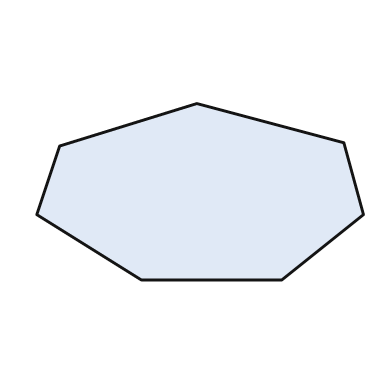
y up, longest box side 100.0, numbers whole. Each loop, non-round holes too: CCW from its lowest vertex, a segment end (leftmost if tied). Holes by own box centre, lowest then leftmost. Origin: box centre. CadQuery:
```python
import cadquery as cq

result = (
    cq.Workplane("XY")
    .moveTo(-18.0, -27.0)
    .lineTo(25.0, -27.0)
    .lineTo(50.0, -7.0)
    .lineTo(44.0, 15.0)
    .lineTo(-1.0, 27.0)
    .lineTo(-43.0, 14.0)
    .lineTo(-50.0, -7.0)
    .close()
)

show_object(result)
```